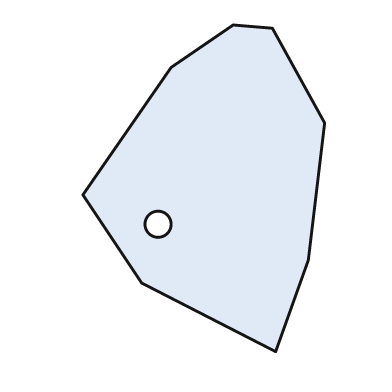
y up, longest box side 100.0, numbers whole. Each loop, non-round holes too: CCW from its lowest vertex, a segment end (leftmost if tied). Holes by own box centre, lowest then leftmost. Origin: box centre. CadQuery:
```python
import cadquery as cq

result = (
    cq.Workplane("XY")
    .moveTo(22.0, -50.0)
    .lineTo(32.0, -22.0)
    .lineTo(37.0, 20.0)
    .lineTo(21.0, 49.0)
    .lineTo(9.0, 50.0)
    .lineTo(-10.0, 37.0)
    .lineTo(-37.0, -2.0)
    .lineTo(-19.0, -29.0)
    .close()
    .moveTo(-14.0, -11.0)
    .circle(4.0)
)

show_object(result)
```